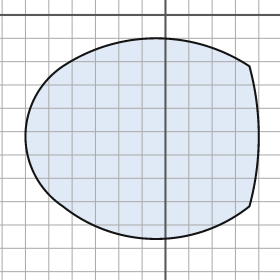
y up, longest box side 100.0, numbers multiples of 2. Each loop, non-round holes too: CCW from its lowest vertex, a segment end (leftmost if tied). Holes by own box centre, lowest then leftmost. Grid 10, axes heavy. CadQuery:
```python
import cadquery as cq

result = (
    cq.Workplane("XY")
    .moveTo(-44.0, -82.0)
    .threePointArc((-4.0, -96.0), (36.0, -82.0))
    .threePointArc((40.0, -52.0), (36.0, -22.0))
    .threePointArc((-4.0, -10.0), (-44.0, -22.0))
    .threePointArc((-60.0, -52.0), (-44.0, -82.0))
    .close()
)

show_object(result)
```